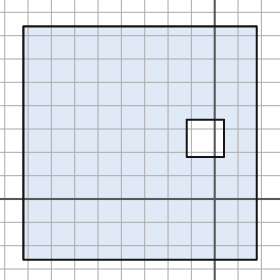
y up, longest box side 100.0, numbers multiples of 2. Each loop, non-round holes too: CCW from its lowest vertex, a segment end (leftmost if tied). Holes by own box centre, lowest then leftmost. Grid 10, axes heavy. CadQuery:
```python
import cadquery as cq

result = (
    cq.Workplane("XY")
    .moveTo(-82.0, -26.0)
    .lineTo(18.0, -26.0)
    .lineTo(18.0, 74.0)
    .lineTo(-82.0, 74.0)
    .close()
    .moveTo(-12.0, 18.0)
    .lineTo(4.0, 18.0)
    .lineTo(4.0, 34.0)
    .lineTo(-12.0, 34.0)
    .close()
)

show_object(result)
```